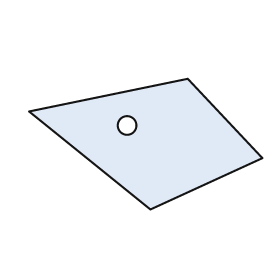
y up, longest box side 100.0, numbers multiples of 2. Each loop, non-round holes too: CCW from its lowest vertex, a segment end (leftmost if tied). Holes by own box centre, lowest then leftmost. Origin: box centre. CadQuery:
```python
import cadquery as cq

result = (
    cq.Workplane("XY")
    .moveTo(2.0, -28.0)
    .lineTo(50.0, -6.0)
    .lineTo(18.0, 28.0)
    .lineTo(-50.0, 14.0)
    .close()
    .moveTo(-8.0, 8.0)
    .circle(4.0)
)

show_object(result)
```